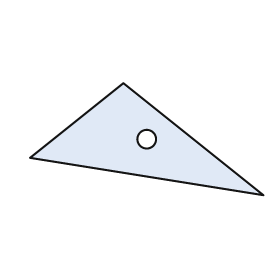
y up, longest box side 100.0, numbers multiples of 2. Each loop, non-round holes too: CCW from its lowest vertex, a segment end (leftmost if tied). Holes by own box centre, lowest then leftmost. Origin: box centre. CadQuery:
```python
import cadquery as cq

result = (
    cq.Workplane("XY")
    .moveTo(50.0, -24.0)
    .lineTo(-10.0, 24.0)
    .lineTo(-50.0, -8.0)
    .close()
    .moveTo(0.0, 0.0)
    .circle(4.0)
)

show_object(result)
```